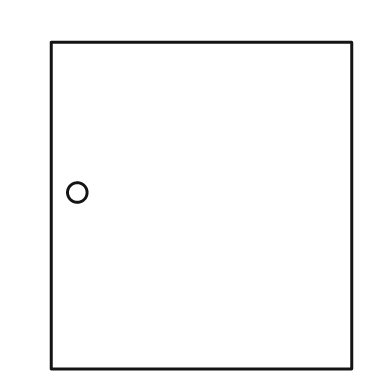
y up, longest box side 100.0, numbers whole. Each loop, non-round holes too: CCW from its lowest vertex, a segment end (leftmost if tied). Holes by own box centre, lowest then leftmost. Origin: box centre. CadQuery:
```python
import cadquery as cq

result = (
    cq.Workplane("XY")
    .moveTo(-46.0, -50.0)
    .lineTo(46.0, -50.0)
    .lineTo(46.0, 50.0)
    .lineTo(-46.0, 50.0)
    .close()
    .moveTo(-38.0, 4.0)
    .circle(3.0)
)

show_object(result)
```